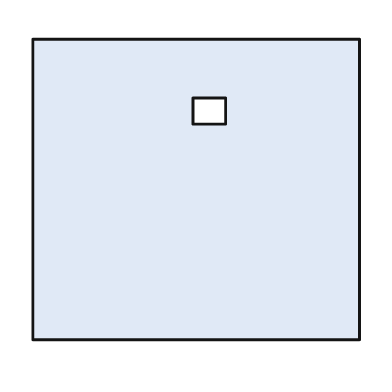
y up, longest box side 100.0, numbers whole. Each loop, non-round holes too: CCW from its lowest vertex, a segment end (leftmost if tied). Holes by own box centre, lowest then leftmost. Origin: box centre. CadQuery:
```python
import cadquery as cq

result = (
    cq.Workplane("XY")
    .moveTo(-50.0, -46.0)
    .lineTo(50.0, -46.0)
    .lineTo(50.0, 46.0)
    .lineTo(-50.0, 46.0)
    .close()
    .moveTo(-1.0, 20.0)
    .lineTo(9.0, 20.0)
    .lineTo(9.0, 28.0)
    .lineTo(-1.0, 28.0)
    .close()
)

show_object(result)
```